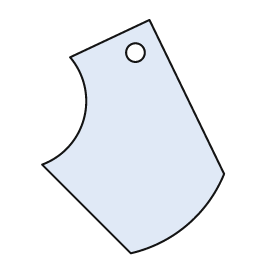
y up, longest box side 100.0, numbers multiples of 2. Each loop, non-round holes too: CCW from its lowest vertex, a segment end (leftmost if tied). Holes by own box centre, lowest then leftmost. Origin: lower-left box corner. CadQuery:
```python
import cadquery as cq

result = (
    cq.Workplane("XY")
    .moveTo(38.0, 0.0)
    .threePointArc((62.0, 12.0), (78.0, 34.0))
    .lineTo(46.0, 100.0)
    .lineTo(12.0, 84.0)
    .threePointArc((18.0, 58.0), (0.0, 38.0))
    .close()
    .moveTo(40.0, 86.0)
    .circle(4.0)
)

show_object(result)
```